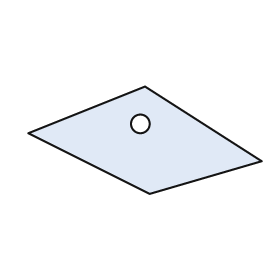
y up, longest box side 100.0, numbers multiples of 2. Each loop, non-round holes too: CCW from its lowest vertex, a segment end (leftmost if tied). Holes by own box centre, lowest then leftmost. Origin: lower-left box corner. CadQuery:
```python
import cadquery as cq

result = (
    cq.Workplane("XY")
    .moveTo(52.0, 0.0)
    .lineTo(100.0, 14.0)
    .lineTo(50.0, 46.0)
    .lineTo(0.0, 26.0)
    .close()
    .moveTo(48.0, 30.0)
    .circle(4.0)
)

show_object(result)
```